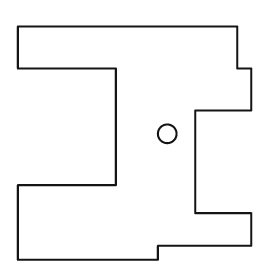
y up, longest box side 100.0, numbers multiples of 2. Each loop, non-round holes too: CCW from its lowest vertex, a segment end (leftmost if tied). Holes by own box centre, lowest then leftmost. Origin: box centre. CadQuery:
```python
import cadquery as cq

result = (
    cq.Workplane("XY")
    .moveTo(-50.0, -50.0)
    .lineTo(10.0, -50.0)
    .lineTo(10.0, -44.0)
    .lineTo(50.0, -44.0)
    .lineTo(50.0, -30.0)
    .lineTo(26.0, -30.0)
    .lineTo(26.0, 14.0)
    .lineTo(50.0, 14.0)
    .lineTo(50.0, 32.0)
    .lineTo(44.0, 32.0)
    .lineTo(44.0, 50.0)
    .lineTo(-50.0, 50.0)
    .lineTo(-50.0, 32.0)
    .lineTo(-8.0, 32.0)
    .lineTo(-8.0, -18.0)
    .lineTo(-50.0, -18.0)
    .close()
    .moveTo(14.0, 4.0)
    .circle(4.0)
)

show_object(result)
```